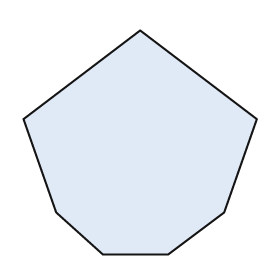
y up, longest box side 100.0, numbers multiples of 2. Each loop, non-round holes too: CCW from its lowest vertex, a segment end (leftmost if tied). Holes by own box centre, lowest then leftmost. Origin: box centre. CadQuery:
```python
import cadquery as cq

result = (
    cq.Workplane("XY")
    .moveTo(-16.0, -48.0)
    .lineTo(12.0, -48.0)
    .lineTo(36.0, -30.0)
    .lineTo(50.0, 10.0)
    .lineTo(0.0, 48.0)
    .lineTo(-50.0, 10.0)
    .lineTo(-36.0, -30.0)
    .close()
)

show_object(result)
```